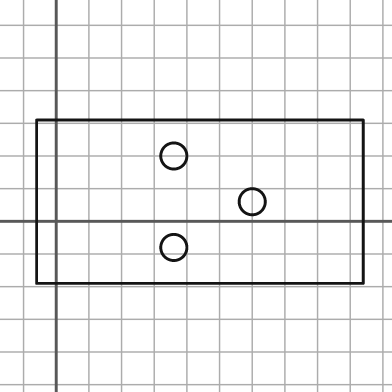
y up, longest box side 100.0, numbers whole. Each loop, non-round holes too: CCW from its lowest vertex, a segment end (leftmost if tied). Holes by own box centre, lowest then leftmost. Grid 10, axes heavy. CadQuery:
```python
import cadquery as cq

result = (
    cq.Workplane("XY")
    .moveTo(-6.0, -19.0)
    .lineTo(94.0, -19.0)
    .lineTo(94.0, 31.0)
    .lineTo(-6.0, 31.0)
    .close()
    .moveTo(36.0, -8.0)
    .circle(4.0)
    .moveTo(60.0, 6.0)
    .circle(4.0)
    .moveTo(36.0, 20.0)
    .circle(4.0)
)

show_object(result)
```